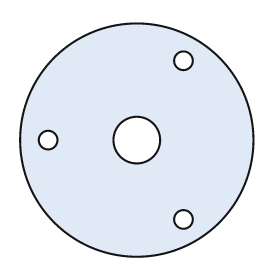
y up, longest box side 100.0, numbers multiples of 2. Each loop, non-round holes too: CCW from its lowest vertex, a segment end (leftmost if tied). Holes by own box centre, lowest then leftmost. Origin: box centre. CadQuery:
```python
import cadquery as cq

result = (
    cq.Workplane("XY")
    .moveTo(0.0, 0.0)
    .circle(50.0)
    .moveTo(20.0, -34.0)
    .circle(4.0)
    .moveTo(-38.0, 0.0)
    .circle(4.0)
    .moveTo(0.0, 0.0)
    .circle(10.0)
    .moveTo(20.0, 34.0)
    .circle(4.0)
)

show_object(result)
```